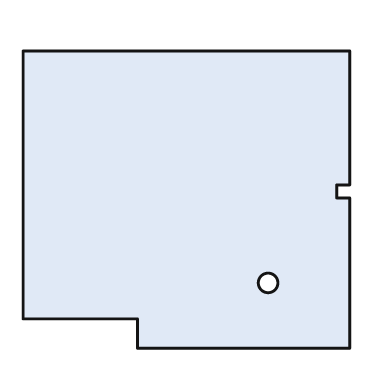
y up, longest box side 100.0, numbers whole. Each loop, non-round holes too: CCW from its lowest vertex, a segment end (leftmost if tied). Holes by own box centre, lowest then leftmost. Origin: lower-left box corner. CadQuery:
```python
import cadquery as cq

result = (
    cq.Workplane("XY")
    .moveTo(35.0, 0.0)
    .lineTo(100.0, 0.0)
    .lineTo(100.0, 46.0)
    .lineTo(96.0, 46.0)
    .lineTo(96.0, 50.0)
    .lineTo(100.0, 50.0)
    .lineTo(100.0, 91.0)
    .lineTo(0.0, 91.0)
    .lineTo(0.0, 9.0)
    .lineTo(35.0, 9.0)
    .close()
    .moveTo(75.0, 20.0)
    .circle(3.0)
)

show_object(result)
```